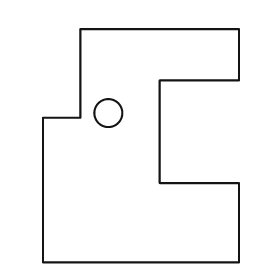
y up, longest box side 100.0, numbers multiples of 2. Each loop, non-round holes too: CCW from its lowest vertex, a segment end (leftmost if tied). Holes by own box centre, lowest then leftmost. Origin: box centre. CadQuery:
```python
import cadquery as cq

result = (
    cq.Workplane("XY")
    .moveTo(-42.0, -50.0)
    .lineTo(42.0, -50.0)
    .lineTo(42.0, -16.0)
    .lineTo(8.0, -16.0)
    .lineTo(8.0, 28.0)
    .lineTo(42.0, 28.0)
    .lineTo(42.0, 50.0)
    .lineTo(-26.0, 50.0)
    .lineTo(-26.0, 12.0)
    .lineTo(-42.0, 12.0)
    .close()
    .moveTo(-14.0, 14.0)
    .circle(6.0)
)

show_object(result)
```